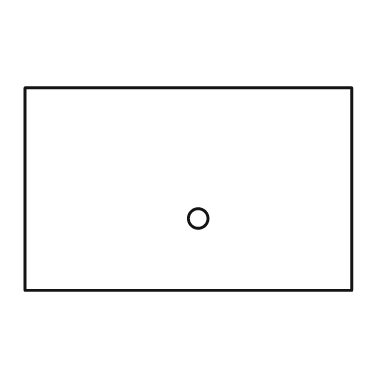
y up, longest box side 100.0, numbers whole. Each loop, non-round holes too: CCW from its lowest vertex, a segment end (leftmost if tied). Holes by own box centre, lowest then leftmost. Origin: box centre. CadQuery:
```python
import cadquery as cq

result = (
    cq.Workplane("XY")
    .moveTo(-50.0, -31.0)
    .lineTo(50.0, -31.0)
    .lineTo(50.0, 31.0)
    .lineTo(-50.0, 31.0)
    .close()
    .moveTo(3.0, -9.0)
    .circle(3.0)
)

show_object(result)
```